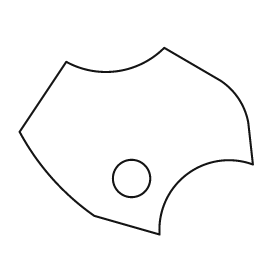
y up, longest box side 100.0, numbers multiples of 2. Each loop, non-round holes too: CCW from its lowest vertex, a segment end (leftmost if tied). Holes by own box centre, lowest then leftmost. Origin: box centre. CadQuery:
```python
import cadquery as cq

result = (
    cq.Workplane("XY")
    .moveTo(10.0, -40.0)
    .threePointArc((22.0, -14.0), (50.0, -10.0))
    .lineTo(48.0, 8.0)
    .threePointArc((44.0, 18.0), (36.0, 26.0))
    .lineTo(12.0, 40.0)
    .threePointArc((-8.0, 30.0), (-30.0, 34.0))
    .lineTo(-50.0, 4.0)
    .threePointArc((-36.0, -16.0), (-18.0, -32.0))
    .close()
    .moveTo(-2.0, -16.0)
    .circle(8.0)
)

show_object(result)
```